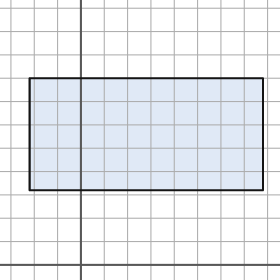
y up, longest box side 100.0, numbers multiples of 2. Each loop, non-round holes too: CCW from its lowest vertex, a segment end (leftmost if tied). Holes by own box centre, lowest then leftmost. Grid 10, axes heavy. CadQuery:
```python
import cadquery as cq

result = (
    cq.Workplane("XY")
    .moveTo(-22.0, 32.0)
    .lineTo(78.0, 32.0)
    .lineTo(78.0, 80.0)
    .lineTo(-22.0, 80.0)
    .close()
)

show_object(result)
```